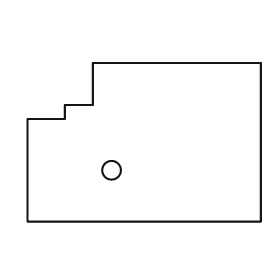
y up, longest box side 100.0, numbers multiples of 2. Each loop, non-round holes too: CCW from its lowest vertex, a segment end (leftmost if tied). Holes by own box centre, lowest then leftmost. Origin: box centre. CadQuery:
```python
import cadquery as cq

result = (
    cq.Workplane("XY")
    .moveTo(-50.0, -34.0)
    .lineTo(50.0, -34.0)
    .lineTo(50.0, 34.0)
    .lineTo(-22.0, 34.0)
    .lineTo(-22.0, 16.0)
    .lineTo(-34.0, 16.0)
    .lineTo(-34.0, 10.0)
    .lineTo(-50.0, 10.0)
    .close()
    .moveTo(-14.0, -12.0)
    .circle(4.0)
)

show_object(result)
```